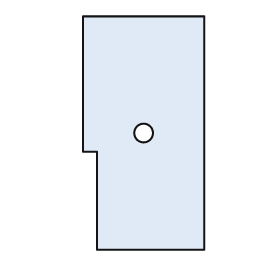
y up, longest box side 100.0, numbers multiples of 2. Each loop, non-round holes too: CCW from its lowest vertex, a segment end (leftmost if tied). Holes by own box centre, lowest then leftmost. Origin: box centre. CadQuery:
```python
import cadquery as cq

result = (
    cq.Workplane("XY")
    .moveTo(-20.0, -50.0)
    .lineTo(26.0, -50.0)
    .lineTo(26.0, 50.0)
    .lineTo(-26.0, 50.0)
    .lineTo(-26.0, -8.0)
    .lineTo(-20.0, -8.0)
    .close()
    .moveTo(0.0, 0.0)
    .circle(4.0)
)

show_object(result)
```